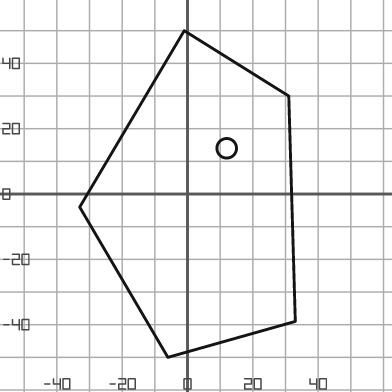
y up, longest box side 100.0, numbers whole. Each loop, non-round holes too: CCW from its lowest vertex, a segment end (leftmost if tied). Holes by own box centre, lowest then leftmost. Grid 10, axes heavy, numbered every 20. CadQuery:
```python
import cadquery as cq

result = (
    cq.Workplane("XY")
    .moveTo(-6.0, -50.0)
    .lineTo(33.0, -39.0)
    .lineTo(31.0, 30.0)
    .lineTo(-1.0, 50.0)
    .lineTo(-33.0, -4.0)
    .close()
    .moveTo(12.0, 14.0)
    .circle(3.0)
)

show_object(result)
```